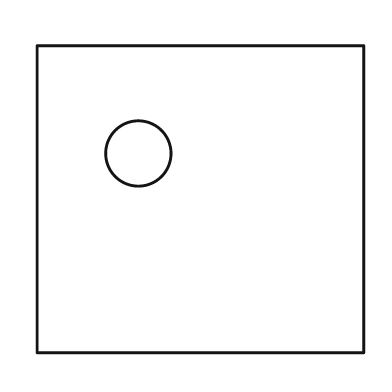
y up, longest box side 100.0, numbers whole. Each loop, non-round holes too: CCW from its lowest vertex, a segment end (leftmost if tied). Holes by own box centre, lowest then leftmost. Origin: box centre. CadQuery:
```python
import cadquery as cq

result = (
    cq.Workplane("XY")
    .moveTo(-50.0, -47.0)
    .lineTo(50.0, -47.0)
    .lineTo(50.0, 47.0)
    .lineTo(-50.0, 47.0)
    .close()
    .moveTo(-19.0, 14.0)
    .circle(10.0)
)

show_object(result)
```